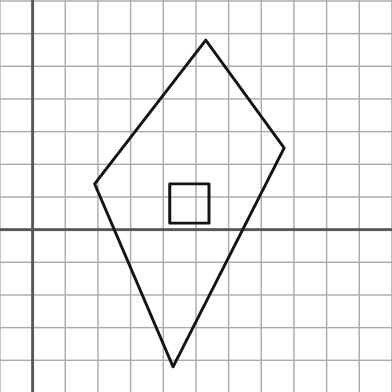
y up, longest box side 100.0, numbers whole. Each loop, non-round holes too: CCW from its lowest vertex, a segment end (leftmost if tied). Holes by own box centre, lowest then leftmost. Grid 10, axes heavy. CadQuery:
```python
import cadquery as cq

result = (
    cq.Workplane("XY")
    .moveTo(43.0, -42.0)
    .lineTo(77.0, 25.0)
    .lineTo(53.0, 58.0)
    .lineTo(19.0, 14.0)
    .close()
    .moveTo(42.0, 2.0)
    .lineTo(54.0, 2.0)
    .lineTo(54.0, 14.0)
    .lineTo(42.0, 14.0)
    .close()
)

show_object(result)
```